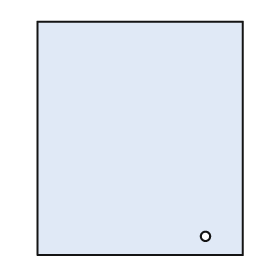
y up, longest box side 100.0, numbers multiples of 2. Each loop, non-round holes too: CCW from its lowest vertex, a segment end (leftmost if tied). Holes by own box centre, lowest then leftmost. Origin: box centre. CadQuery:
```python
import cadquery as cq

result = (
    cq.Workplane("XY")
    .moveTo(-44.0, -50.0)
    .lineTo(44.0, -50.0)
    .lineTo(44.0, 50.0)
    .lineTo(-44.0, 50.0)
    .close()
    .moveTo(28.0, -42.0)
    .circle(2.0)
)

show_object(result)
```